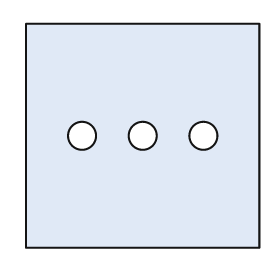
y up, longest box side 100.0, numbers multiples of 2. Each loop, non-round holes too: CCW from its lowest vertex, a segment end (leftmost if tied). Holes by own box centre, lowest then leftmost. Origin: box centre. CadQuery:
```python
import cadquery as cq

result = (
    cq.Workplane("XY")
    .moveTo(-50.0, -48.0)
    .lineTo(50.0, -48.0)
    .lineTo(50.0, 48.0)
    .lineTo(-50.0, 48.0)
    .close()
    .moveTo(-26.0, 0.0)
    .circle(6.0)
    .moveTo(0.0, 0.0)
    .circle(6.0)
    .moveTo(26.0, 0.0)
    .circle(6.0)
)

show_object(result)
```